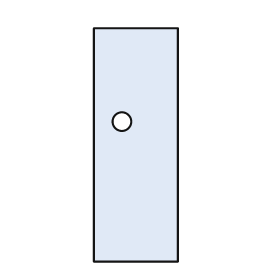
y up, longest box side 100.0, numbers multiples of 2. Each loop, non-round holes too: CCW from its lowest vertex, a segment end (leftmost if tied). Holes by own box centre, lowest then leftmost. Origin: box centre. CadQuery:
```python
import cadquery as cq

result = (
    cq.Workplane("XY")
    .moveTo(-18.0, -50.0)
    .lineTo(18.0, -50.0)
    .lineTo(18.0, 50.0)
    .lineTo(-18.0, 50.0)
    .close()
    .moveTo(-6.0, 10.0)
    .circle(4.0)
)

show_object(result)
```